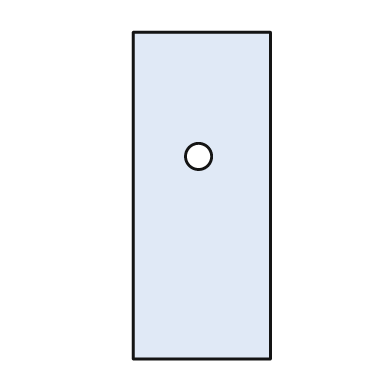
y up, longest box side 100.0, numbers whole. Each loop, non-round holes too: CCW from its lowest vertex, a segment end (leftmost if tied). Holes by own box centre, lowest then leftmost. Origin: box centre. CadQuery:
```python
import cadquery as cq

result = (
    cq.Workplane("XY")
    .moveTo(-21.0, -50.0)
    .lineTo(21.0, -50.0)
    .lineTo(21.0, 50.0)
    .lineTo(-21.0, 50.0)
    .close()
    .moveTo(-1.0, 12.0)
    .circle(4.0)
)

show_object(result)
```